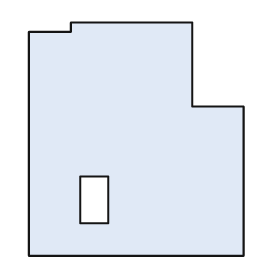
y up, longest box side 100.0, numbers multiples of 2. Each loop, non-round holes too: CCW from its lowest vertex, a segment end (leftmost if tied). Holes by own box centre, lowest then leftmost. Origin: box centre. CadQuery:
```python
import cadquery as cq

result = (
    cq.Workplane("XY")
    .moveTo(-46.0, -50.0)
    .lineTo(46.0, -50.0)
    .lineTo(46.0, 14.0)
    .lineTo(24.0, 14.0)
    .lineTo(24.0, 50.0)
    .lineTo(-28.0, 50.0)
    .lineTo(-28.0, 46.0)
    .lineTo(-46.0, 46.0)
    .close()
    .moveTo(-24.0, -36.0)
    .lineTo(-12.0, -36.0)
    .lineTo(-12.0, -16.0)
    .lineTo(-24.0, -16.0)
    .close()
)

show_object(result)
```